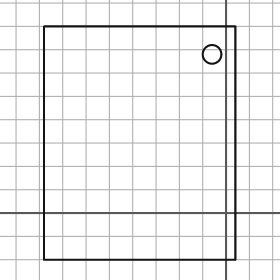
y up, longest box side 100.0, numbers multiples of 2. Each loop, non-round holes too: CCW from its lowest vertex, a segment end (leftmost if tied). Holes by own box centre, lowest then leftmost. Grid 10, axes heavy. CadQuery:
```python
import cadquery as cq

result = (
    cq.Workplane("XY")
    .moveTo(-78.0, -20.0)
    .lineTo(4.0, -20.0)
    .lineTo(4.0, 80.0)
    .lineTo(-78.0, 80.0)
    .close()
    .moveTo(-6.0, 68.0)
    .circle(4.0)
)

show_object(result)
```